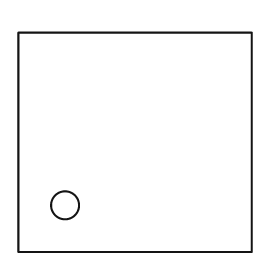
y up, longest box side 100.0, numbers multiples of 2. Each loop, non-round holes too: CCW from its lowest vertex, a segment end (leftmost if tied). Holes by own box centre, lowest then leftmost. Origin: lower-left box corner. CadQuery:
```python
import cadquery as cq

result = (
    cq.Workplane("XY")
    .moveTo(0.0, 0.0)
    .lineTo(100.0, 0.0)
    .lineTo(100.0, 94.0)
    .lineTo(0.0, 94.0)
    .close()
    .moveTo(20.0, 20.0)
    .circle(6.0)
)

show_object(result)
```